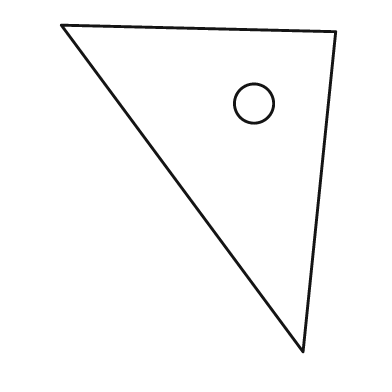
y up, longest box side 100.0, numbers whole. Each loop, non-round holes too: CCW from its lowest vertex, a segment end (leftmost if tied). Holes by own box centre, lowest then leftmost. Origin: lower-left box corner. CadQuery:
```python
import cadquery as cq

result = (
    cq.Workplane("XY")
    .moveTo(74.0, 0.0)
    .lineTo(84.0, 98.0)
    .lineTo(0.0, 100.0)
    .close()
    .moveTo(59.0, 76.0)
    .circle(6.0)
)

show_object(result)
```